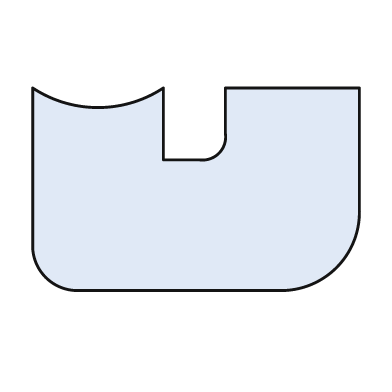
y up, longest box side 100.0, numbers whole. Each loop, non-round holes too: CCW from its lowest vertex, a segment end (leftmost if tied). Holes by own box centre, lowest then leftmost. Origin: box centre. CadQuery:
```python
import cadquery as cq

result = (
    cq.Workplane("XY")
    .moveTo(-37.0, -31.0)
    .lineTo(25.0, -31.0)
    .threePointArc((43.0, -24.0), (50.0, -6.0))
    .lineTo(50.0, 31.0)
    .lineTo(9.0, 31.0)
    .lineTo(9.0, 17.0)
    .threePointArc((7.0, 11.0), (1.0, 9.0))
    .lineTo(-10.0, 9.0)
    .lineTo(-10.0, 31.0)
    .threePointArc((-30.0, 25.0), (-50.0, 31.0))
    .lineTo(-50.0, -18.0)
    .threePointArc((-46.0, -27.0), (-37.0, -31.0))
    .close()
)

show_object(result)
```